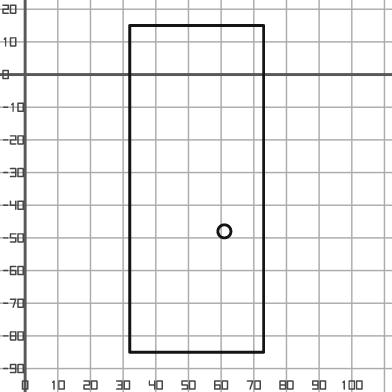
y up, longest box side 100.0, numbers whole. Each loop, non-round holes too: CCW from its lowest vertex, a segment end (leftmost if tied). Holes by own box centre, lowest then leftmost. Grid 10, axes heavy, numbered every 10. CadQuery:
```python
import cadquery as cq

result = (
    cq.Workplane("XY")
    .moveTo(32.0, -85.0)
    .lineTo(73.0, -85.0)
    .lineTo(73.0, 15.0)
    .lineTo(32.0, 15.0)
    .close()
    .moveTo(61.0, -48.0)
    .circle(2.0)
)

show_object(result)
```